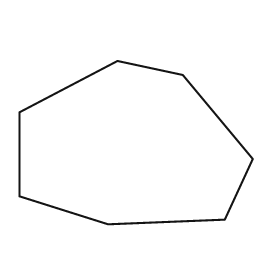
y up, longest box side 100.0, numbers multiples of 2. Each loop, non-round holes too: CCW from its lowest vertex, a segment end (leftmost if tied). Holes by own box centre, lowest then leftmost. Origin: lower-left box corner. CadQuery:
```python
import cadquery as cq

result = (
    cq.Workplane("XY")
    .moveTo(38.0, 0.0)
    .lineTo(88.0, 2.0)
    .lineTo(100.0, 28.0)
    .lineTo(70.0, 64.0)
    .lineTo(42.0, 70.0)
    .lineTo(0.0, 48.0)
    .lineTo(0.0, 12.0)
    .close()
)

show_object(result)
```